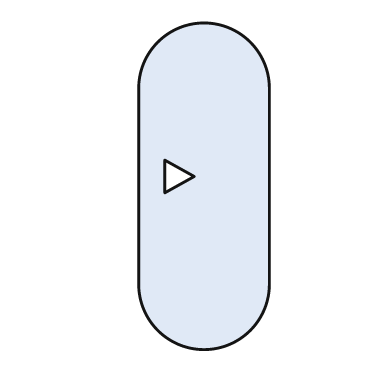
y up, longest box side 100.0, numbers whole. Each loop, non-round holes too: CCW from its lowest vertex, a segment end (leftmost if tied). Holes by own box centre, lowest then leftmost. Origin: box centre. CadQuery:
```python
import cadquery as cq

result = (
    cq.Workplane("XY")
    .moveTo(-20.0, -30.0)
    .threePointArc((0.0, -50.0), (20.0, -30.0))
    .lineTo(20.0, 30.0)
    .threePointArc((0.0, 50.0), (-20.0, 30.0))
    .close()
    .moveTo(-12.0, -2.0)
    .lineTo(-3.0, 3.0)
    .lineTo(-12.0, 8.0)
    .close()
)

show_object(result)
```